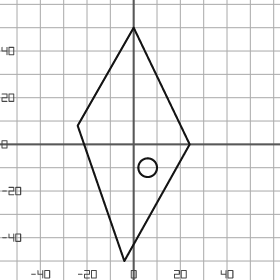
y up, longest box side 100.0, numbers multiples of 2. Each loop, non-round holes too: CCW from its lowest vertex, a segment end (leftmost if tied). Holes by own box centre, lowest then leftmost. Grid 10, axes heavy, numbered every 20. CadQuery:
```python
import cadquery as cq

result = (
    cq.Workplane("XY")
    .moveTo(-4.0, -50.0)
    .lineTo(24.0, 0.0)
    .lineTo(0.0, 50.0)
    .lineTo(-24.0, 8.0)
    .close()
    .moveTo(6.0, -10.0)
    .circle(4.0)
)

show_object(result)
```